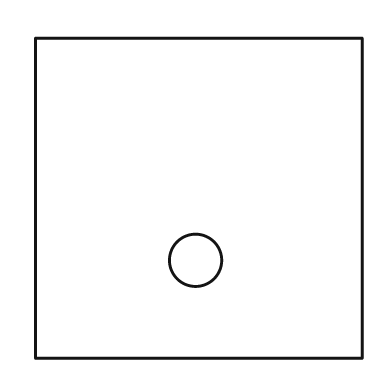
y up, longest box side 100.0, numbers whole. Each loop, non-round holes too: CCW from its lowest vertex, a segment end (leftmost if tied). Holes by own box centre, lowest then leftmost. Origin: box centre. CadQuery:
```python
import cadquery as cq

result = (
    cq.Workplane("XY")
    .moveTo(-50.0, -49.0)
    .lineTo(50.0, -49.0)
    .lineTo(50.0, 49.0)
    .lineTo(-50.0, 49.0)
    .close()
    .moveTo(-1.0, -19.0)
    .circle(8.0)
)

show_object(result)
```